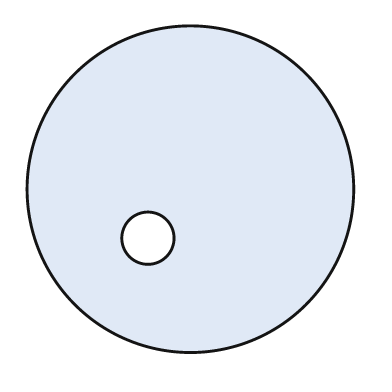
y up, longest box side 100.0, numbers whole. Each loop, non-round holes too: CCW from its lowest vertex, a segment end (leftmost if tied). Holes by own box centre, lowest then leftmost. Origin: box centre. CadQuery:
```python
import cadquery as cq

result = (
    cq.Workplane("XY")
    .moveTo(0.0, 0.0)
    .circle(50.0)
    .moveTo(-13.0, -15.0)
    .circle(8.0)
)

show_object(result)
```